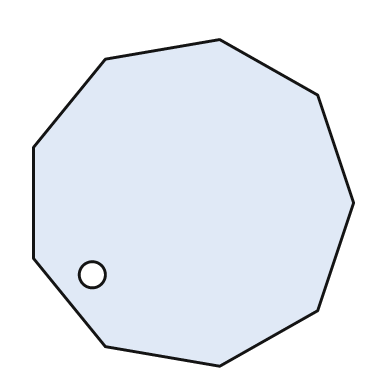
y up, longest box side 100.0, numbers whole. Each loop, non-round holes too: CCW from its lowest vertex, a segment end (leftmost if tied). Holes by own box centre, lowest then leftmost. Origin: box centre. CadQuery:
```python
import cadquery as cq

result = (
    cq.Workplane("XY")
    .moveTo(8.0, -50.0)
    .lineTo(38.0, -33.0)
    .lineTo(49.0, 0.0)
    .lineTo(38.0, 33.0)
    .lineTo(8.0, 50.0)
    .lineTo(-27.0, 44.0)
    .lineTo(-49.0, 17.0)
    .lineTo(-49.0, -17.0)
    .lineTo(-27.0, -44.0)
    .close()
    .moveTo(-31.0, -22.0)
    .circle(4.0)
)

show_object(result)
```